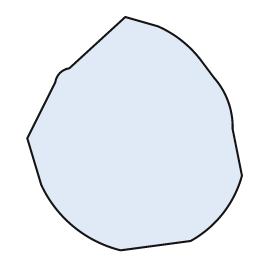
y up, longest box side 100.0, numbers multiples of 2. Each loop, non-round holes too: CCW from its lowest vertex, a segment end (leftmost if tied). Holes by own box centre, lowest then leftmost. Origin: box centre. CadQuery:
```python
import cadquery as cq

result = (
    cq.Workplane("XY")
    .moveTo(-6.0, -50.0)
    .lineTo(24.0, -46.0)
    .threePointArc((38.0, -34.0), (46.0, -18.0))
    .lineTo(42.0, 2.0)
    .threePointArc((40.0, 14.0), (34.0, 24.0))
    .lineTo(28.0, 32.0)
    .threePointArc((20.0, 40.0), (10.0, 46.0))
    .lineTo(-4.0, 50.0)
    .lineTo(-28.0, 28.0)
    .threePointArc((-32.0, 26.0), (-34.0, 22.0))
    .lineTo(-46.0, -2.0)
    .lineTo(-40.0, -22.0)
    .threePointArc((-26.0, -40.0), (-6.0, -50.0))
    .close()
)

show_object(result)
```